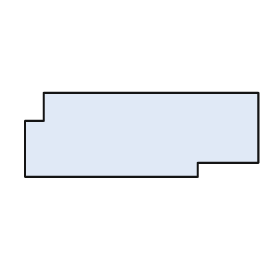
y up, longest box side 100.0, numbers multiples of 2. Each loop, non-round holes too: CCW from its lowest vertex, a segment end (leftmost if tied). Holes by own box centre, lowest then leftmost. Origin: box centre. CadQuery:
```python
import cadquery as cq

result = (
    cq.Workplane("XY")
    .moveTo(-50.0, -18.0)
    .lineTo(24.0, -18.0)
    .lineTo(24.0, -12.0)
    .lineTo(50.0, -12.0)
    .lineTo(50.0, 18.0)
    .lineTo(-42.0, 18.0)
    .lineTo(-42.0, 6.0)
    .lineTo(-50.0, 6.0)
    .close()
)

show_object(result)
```